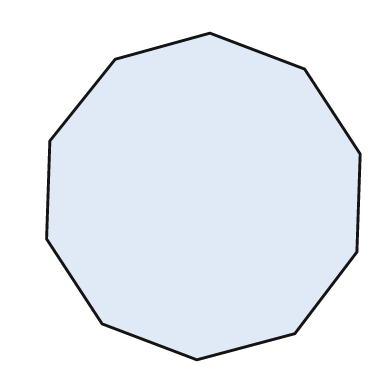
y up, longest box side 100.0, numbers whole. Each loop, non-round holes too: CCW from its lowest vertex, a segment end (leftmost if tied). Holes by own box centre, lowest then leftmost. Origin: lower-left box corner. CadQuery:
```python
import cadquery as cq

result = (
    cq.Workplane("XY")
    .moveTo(46.0, 0.0)
    .lineTo(76.0, 8.0)
    .lineTo(95.0, 33.0)
    .lineTo(96.0, 63.0)
    .lineTo(79.0, 89.0)
    .lineTo(50.0, 100.0)
    .lineTo(21.0, 92.0)
    .lineTo(1.0, 67.0)
    .lineTo(0.0, 37.0)
    .lineTo(17.0, 11.0)
    .close()
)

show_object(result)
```